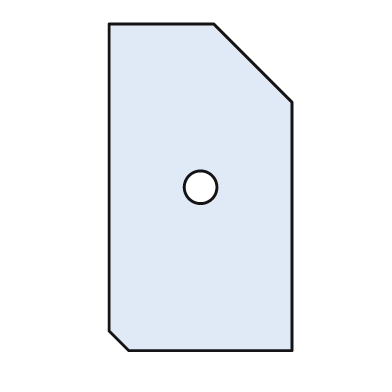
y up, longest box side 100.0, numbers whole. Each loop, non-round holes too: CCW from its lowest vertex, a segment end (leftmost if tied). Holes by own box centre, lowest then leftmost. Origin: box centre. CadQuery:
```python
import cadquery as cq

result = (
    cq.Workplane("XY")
    .moveTo(-22.0, -50.0)
    .lineTo(28.0, -50.0)
    .lineTo(28.0, 26.0)
    .lineTo(4.0, 50.0)
    .lineTo(-28.0, 50.0)
    .lineTo(-28.0, -44.0)
    .close()
    .moveTo(0.0, 0.0)
    .circle(5.0)
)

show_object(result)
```